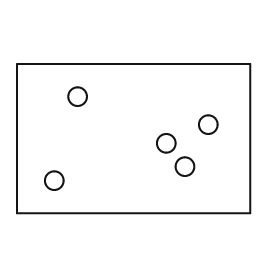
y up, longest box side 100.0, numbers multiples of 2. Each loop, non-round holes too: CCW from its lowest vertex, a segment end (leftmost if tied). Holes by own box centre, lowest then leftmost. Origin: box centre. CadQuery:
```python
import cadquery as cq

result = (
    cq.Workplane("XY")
    .moveTo(-50.0, -32.0)
    .lineTo(50.0, -32.0)
    .lineTo(50.0, 32.0)
    .lineTo(-50.0, 32.0)
    .close()
    .moveTo(-34.0, -18.0)
    .circle(4.0)
    .moveTo(22.0, -12.0)
    .circle(4.0)
    .moveTo(14.0, -2.0)
    .circle(4.0)
    .moveTo(32.0, 6.0)
    .circle(4.0)
    .moveTo(-24.0, 18.0)
    .circle(4.0)
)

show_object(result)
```